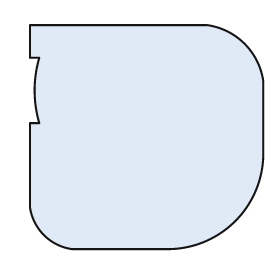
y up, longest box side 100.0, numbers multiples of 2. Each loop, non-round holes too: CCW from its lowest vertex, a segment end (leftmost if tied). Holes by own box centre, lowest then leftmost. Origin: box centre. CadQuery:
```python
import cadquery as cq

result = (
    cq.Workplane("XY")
    .moveTo(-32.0, -48.0)
    .lineTo(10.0, -48.0)
    .threePointArc((38.0, -36.0), (50.0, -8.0))
    .lineTo(50.0, 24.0)
    .threePointArc((42.0, 40.0), (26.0, 48.0))
    .lineTo(-50.0, 48.0)
    .lineTo(-50.0, 34.0)
    .lineTo(-46.0, 34.0)
    .threePointArc((-48.0, 20.0), (-46.0, 6.0))
    .lineTo(-50.0, 6.0)
    .lineTo(-50.0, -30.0)
    .threePointArc((-44.0, -42.0), (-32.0, -48.0))
    .close()
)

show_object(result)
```